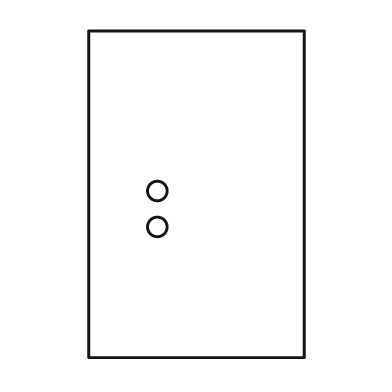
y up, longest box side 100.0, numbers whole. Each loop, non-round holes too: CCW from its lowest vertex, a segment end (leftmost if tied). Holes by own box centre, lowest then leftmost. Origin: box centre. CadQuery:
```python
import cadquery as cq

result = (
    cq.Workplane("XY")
    .moveTo(-33.0, -50.0)
    .lineTo(33.0, -50.0)
    .lineTo(33.0, 50.0)
    .lineTo(-33.0, 50.0)
    .close()
    .moveTo(-12.0, -10.0)
    .circle(3.0)
    .moveTo(-12.0, 1.0)
    .circle(3.0)
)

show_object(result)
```